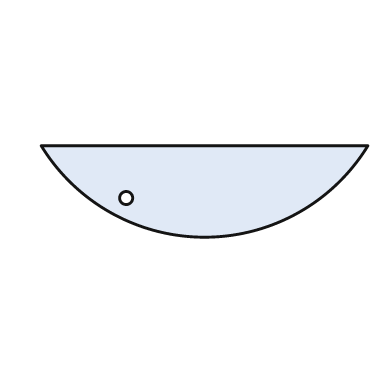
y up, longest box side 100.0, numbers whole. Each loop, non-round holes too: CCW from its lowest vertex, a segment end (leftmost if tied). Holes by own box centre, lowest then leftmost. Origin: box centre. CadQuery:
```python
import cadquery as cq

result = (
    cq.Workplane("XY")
    .moveTo(-50.0, 14.0)
    .threePointArc((0.0, -14.0), (50.0, 14.0))
    .close()
    .moveTo(-24.0, -2.0)
    .circle(2.0)
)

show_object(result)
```